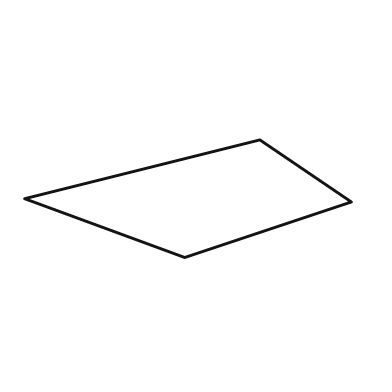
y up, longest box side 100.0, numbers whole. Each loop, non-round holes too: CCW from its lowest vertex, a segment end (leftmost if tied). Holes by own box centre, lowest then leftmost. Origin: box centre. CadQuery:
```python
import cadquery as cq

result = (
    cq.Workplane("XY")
    .moveTo(-1.0, -18.0)
    .lineTo(50.0, -1.0)
    .lineTo(22.0, 18.0)
    .lineTo(-50.0, 0.0)
    .close()
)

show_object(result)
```